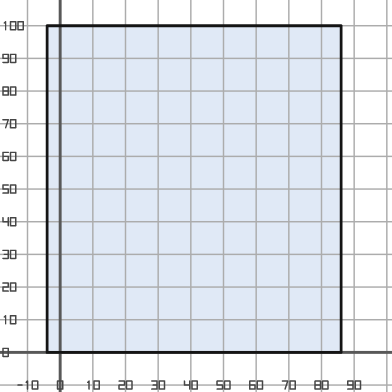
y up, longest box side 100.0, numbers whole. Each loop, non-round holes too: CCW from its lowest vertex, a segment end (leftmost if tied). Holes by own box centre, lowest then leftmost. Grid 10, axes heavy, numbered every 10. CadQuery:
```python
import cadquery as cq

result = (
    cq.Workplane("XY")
    .moveTo(-4.0, 0.0)
    .lineTo(86.0, 0.0)
    .lineTo(86.0, 100.0)
    .lineTo(-4.0, 100.0)
    .close()
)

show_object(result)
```